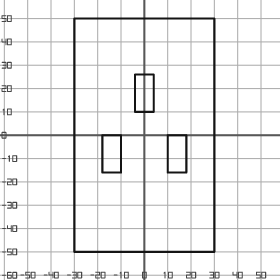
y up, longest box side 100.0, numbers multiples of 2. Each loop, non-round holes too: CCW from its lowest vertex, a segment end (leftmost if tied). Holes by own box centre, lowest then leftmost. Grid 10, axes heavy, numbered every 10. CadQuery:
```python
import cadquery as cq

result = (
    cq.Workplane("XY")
    .moveTo(-30.0, -50.0)
    .lineTo(30.0, -50.0)
    .lineTo(30.0, 50.0)
    .lineTo(-30.0, 50.0)
    .close()
    .moveTo(-18.0, -16.0)
    .lineTo(-10.0, -16.0)
    .lineTo(-10.0, 0.0)
    .lineTo(-18.0, 0.0)
    .close()
    .moveTo(10.0, -16.0)
    .lineTo(18.0, -16.0)
    .lineTo(18.0, 0.0)
    .lineTo(10.0, 0.0)
    .close()
    .moveTo(-4.0, 10.0)
    .lineTo(4.0, 10.0)
    .lineTo(4.0, 26.0)
    .lineTo(-4.0, 26.0)
    .close()
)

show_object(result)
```